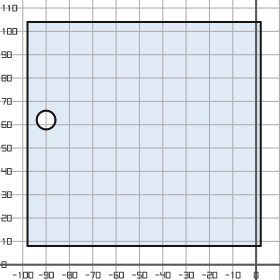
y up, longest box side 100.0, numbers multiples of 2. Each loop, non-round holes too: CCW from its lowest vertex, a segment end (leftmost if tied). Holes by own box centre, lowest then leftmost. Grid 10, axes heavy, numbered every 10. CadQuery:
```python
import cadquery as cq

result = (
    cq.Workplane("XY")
    .moveTo(-98.0, 8.0)
    .lineTo(2.0, 8.0)
    .lineTo(2.0, 104.0)
    .lineTo(-98.0, 104.0)
    .close()
    .moveTo(-90.0, 62.0)
    .circle(4.0)
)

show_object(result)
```